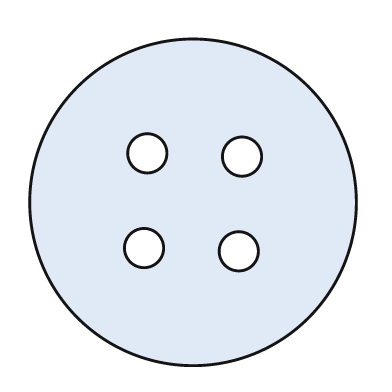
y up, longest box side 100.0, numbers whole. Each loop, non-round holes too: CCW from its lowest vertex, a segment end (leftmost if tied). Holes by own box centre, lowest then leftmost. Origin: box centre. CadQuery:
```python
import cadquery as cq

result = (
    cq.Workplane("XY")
    .moveTo(0.0, 0.0)
    .circle(50.0)
    .moveTo(14.0, -15.0)
    .circle(6.0)
    .moveTo(-15.0, -14.0)
    .circle(6.0)
    .moveTo(15.0, 14.0)
    .circle(6.0)
    .moveTo(-14.0, 15.0)
    .circle(6.0)
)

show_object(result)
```